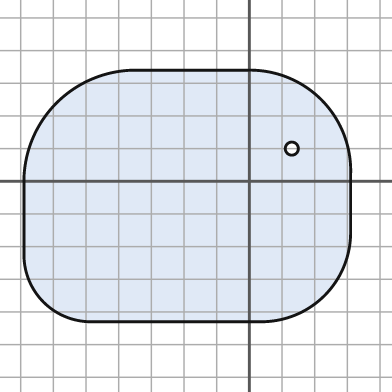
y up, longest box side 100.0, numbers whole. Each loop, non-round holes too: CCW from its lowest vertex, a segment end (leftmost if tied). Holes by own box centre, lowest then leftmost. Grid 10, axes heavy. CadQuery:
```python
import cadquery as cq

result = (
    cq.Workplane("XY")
    .moveTo(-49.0, -43.0)
    .lineTo(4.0, -43.0)
    .threePointArc((23.0, -35.0), (31.0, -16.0))
    .lineTo(31.0, 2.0)
    .threePointArc((22.0, 25.0), (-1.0, 34.0))
    .lineTo(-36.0, 34.0)
    .threePointArc((-59.0, 24.0), (-69.0, 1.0))
    .lineTo(-69.0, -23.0)
    .threePointArc((-63.0, -37.0), (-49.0, -43.0))
    .close()
    .moveTo(13.0, 10.0)
    .circle(2.0)
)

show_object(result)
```